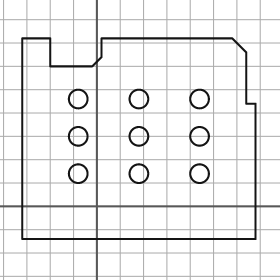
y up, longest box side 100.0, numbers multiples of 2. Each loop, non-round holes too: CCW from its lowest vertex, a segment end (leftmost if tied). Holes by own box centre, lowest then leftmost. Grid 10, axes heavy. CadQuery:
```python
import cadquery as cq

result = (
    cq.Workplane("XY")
    .moveTo(-32.0, -14.0)
    .lineTo(68.0, -14.0)
    .lineTo(68.0, 44.0)
    .lineTo(64.0, 44.0)
    .lineTo(64.0, 66.0)
    .lineTo(58.0, 72.0)
    .lineTo(2.0, 72.0)
    .lineTo(2.0, 64.0)
    .lineTo(-2.0, 60.0)
    .lineTo(-20.0, 60.0)
    .lineTo(-20.0, 72.0)
    .lineTo(-32.0, 72.0)
    .close()
    .moveTo(-8.0, 14.0)
    .circle(4.0)
    .moveTo(18.0, 14.0)
    .circle(4.0)
    .moveTo(44.0, 14.0)
    .circle(4.0)
    .moveTo(-8.0, 30.0)
    .circle(4.0)
    .moveTo(18.0, 30.0)
    .circle(4.0)
    .moveTo(44.0, 30.0)
    .circle(4.0)
    .moveTo(-8.0, 46.0)
    .circle(4.0)
    .moveTo(18.0, 46.0)
    .circle(4.0)
    .moveTo(44.0, 46.0)
    .circle(4.0)
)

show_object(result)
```